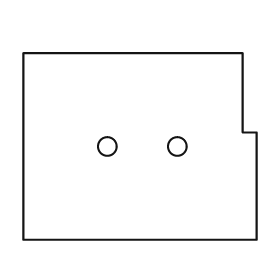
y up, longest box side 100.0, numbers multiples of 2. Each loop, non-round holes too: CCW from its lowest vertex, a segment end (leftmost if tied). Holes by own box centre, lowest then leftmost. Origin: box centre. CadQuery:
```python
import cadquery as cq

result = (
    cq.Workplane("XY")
    .moveTo(-50.0, -40.0)
    .lineTo(50.0, -40.0)
    .lineTo(50.0, 6.0)
    .lineTo(44.0, 6.0)
    .lineTo(44.0, 40.0)
    .lineTo(-50.0, 40.0)
    .close()
    .moveTo(-14.0, 0.0)
    .circle(4.0)
    .moveTo(16.0, 0.0)
    .circle(4.0)
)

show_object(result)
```